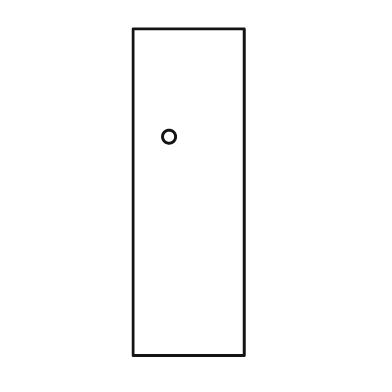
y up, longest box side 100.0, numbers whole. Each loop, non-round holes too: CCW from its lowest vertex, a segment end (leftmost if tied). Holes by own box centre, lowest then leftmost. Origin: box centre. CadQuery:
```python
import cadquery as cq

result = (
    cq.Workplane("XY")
    .moveTo(-17.0, -50.0)
    .lineTo(17.0, -50.0)
    .lineTo(17.0, 50.0)
    .lineTo(-17.0, 50.0)
    .close()
    .moveTo(-6.0, 17.0)
    .circle(2.0)
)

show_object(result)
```